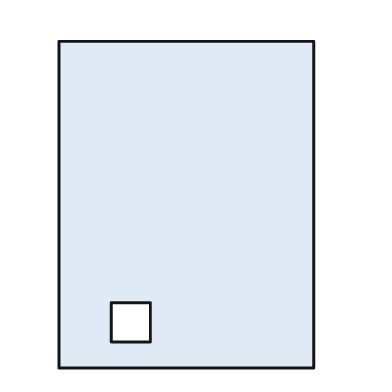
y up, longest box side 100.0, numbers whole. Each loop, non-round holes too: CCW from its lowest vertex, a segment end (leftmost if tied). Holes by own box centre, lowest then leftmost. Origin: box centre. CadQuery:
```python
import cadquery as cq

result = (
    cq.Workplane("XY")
    .moveTo(-39.0, -50.0)
    .lineTo(39.0, -50.0)
    .lineTo(39.0, 50.0)
    .lineTo(-39.0, 50.0)
    .close()
    .moveTo(-23.0, -42.0)
    .lineTo(-11.0, -42.0)
    .lineTo(-11.0, -30.0)
    .lineTo(-23.0, -30.0)
    .close()
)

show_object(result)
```